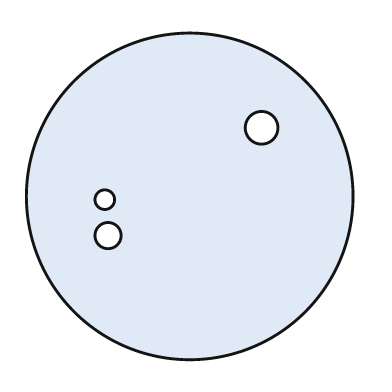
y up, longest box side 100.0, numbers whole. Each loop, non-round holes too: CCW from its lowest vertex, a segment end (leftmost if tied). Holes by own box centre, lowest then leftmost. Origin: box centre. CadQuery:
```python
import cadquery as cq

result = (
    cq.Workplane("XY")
    .moveTo(0.0, 0.0)
    .circle(50.0)
    .moveTo(-25.0, -12.0)
    .circle(4.0)
    .moveTo(-26.0, -1.0)
    .circle(3.0)
    .moveTo(22.0, 21.0)
    .circle(5.0)
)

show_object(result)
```